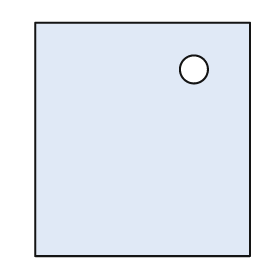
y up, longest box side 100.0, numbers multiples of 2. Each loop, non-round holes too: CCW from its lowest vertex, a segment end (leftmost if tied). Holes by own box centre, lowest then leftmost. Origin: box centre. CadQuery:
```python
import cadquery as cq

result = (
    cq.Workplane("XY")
    .moveTo(-46.0, -50.0)
    .lineTo(46.0, -50.0)
    .lineTo(46.0, 50.0)
    .lineTo(-46.0, 50.0)
    .close()
    .moveTo(22.0, 30.0)
    .circle(6.0)
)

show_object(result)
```